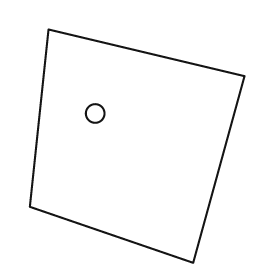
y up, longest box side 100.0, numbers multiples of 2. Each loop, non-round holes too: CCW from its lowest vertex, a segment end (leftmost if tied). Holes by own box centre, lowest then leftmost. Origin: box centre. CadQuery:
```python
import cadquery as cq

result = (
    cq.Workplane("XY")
    .moveTo(24.0, -50.0)
    .lineTo(46.0, 30.0)
    .lineTo(-38.0, 50.0)
    .lineTo(-46.0, -26.0)
    .close()
    .moveTo(-18.0, 14.0)
    .circle(4.0)
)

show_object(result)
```